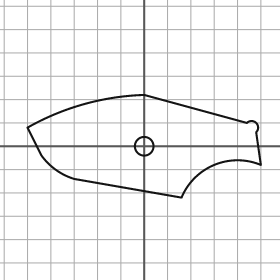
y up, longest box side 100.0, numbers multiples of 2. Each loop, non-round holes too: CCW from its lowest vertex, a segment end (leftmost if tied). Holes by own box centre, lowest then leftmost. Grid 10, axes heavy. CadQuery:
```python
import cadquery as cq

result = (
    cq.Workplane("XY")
    .moveTo(16.0, -22.0)
    .threePointArc((30.0, -8.0), (50.0, -8.0))
    .lineTo(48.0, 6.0)
    .threePointArc((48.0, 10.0), (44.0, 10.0))
    .lineTo(0.0, 22.0)
    .threePointArc((-26.0, 18.0), (-50.0, 8.0))
    .lineTo(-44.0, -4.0)
    .threePointArc((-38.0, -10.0), (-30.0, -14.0))
    .close()
    .moveTo(0.0, 0.0)
    .circle(4.0)
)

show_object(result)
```